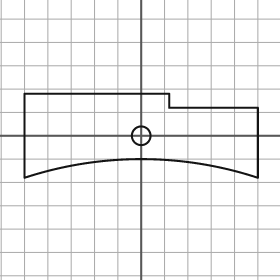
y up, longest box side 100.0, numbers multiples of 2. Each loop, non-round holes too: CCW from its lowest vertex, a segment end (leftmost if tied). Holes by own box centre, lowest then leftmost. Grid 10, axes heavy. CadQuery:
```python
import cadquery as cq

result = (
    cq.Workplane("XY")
    .moveTo(-50.0, -18.0)
    .threePointArc((0.0, -10.0), (50.0, -18.0))
    .lineTo(50.0, 12.0)
    .lineTo(12.0, 12.0)
    .lineTo(12.0, 18.0)
    .lineTo(-50.0, 18.0)
    .close()
    .moveTo(0.0, 0.0)
    .circle(4.0)
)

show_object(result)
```